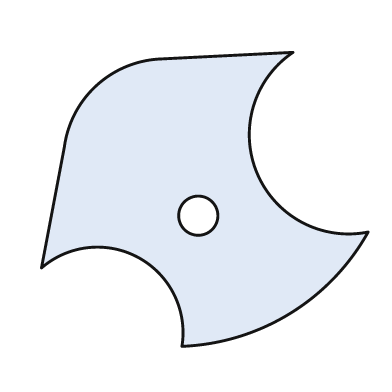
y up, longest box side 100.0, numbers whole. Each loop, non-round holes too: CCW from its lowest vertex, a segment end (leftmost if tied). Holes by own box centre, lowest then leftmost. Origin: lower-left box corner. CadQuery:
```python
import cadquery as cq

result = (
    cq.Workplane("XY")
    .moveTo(43.0, 0.0)
    .threePointArc((76.0, 10.0), (100.0, 35.0))
    .threePointArc((66.0, 53.0), (77.0, 90.0))
    .lineTo(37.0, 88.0)
    .threePointArc((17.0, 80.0), (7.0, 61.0))
    .lineTo(0.0, 24.0)
    .threePointArc((30.0, 27.0), (43.0, 0.0))
    .close()
    .moveTo(48.0, 40.0)
    .circle(6.0)
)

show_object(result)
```